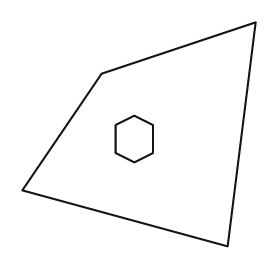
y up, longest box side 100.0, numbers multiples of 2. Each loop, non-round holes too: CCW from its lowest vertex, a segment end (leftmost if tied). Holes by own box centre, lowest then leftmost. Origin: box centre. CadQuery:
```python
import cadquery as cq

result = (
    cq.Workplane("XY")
    .moveTo(38.0, -48.0)
    .lineTo(50.0, 48.0)
    .lineTo(-16.0, 26.0)
    .lineTo(-50.0, -24.0)
    .close()
    .moveTo(-2.0, -12.0)
    .lineTo(6.0, -8.0)
    .lineTo(6.0, 4.0)
    .lineTo(-2.0, 8.0)
    .lineTo(-10.0, 4.0)
    .lineTo(-10.0, -8.0)
    .close()
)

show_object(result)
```